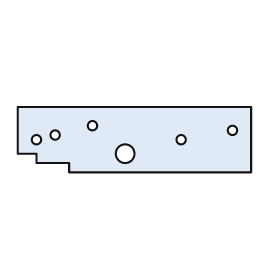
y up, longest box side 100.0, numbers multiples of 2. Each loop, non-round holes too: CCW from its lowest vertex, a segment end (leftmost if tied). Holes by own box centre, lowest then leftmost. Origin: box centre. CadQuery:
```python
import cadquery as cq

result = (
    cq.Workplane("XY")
    .moveTo(-28.0, -14.0)
    .lineTo(50.0, -14.0)
    .lineTo(50.0, 14.0)
    .lineTo(-50.0, 14.0)
    .lineTo(-50.0, -6.0)
    .lineTo(-42.0, -6.0)
    .lineTo(-42.0, -10.0)
    .lineTo(-28.0, -10.0)
    .close()
    .moveTo(-4.0, -6.0)
    .circle(4.0)
    .moveTo(-42.0, 0.0)
    .circle(2.0)
    .moveTo(20.0, 0.0)
    .circle(2.0)
    .moveTo(-34.0, 2.0)
    .circle(2.0)
    .moveTo(42.0, 4.0)
    .circle(2.0)
    .moveTo(-18.0, 6.0)
    .circle(2.0)
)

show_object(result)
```